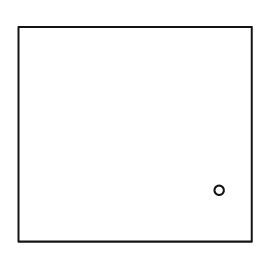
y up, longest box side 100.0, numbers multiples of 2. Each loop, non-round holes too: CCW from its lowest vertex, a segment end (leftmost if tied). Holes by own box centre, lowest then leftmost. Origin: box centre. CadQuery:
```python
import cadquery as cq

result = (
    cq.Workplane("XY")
    .moveTo(-50.0, -46.0)
    .lineTo(50.0, -46.0)
    .lineTo(50.0, 46.0)
    .lineTo(-50.0, 46.0)
    .close()
    .moveTo(36.0, -24.0)
    .circle(2.0)
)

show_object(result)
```